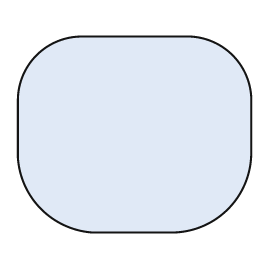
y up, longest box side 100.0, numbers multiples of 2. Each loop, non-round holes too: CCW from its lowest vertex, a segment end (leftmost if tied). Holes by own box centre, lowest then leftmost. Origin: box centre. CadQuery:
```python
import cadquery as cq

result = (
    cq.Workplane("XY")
    .moveTo(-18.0, -42.0)
    .lineTo(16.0, -42.0)
    .threePointArc((40.0, -32.0), (50.0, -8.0))
    .lineTo(50.0, 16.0)
    .threePointArc((42.0, 34.0), (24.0, 42.0))
    .lineTo(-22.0, 42.0)
    .threePointArc((-42.0, 34.0), (-50.0, 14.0))
    .lineTo(-50.0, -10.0)
    .threePointArc((-40.0, -32.0), (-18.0, -42.0))
    .close()
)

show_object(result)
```